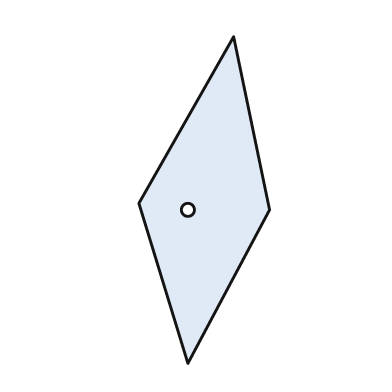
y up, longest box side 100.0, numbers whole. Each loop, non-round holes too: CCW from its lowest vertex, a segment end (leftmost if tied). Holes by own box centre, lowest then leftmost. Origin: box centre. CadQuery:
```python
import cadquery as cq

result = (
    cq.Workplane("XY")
    .moveTo(-5.0, -50.0)
    .lineTo(20.0, -3.0)
    .lineTo(9.0, 50.0)
    .lineTo(-20.0, -1.0)
    .close()
    .moveTo(-5.0, -3.0)
    .circle(2.0)
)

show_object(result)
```